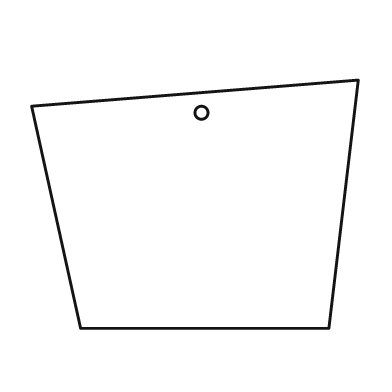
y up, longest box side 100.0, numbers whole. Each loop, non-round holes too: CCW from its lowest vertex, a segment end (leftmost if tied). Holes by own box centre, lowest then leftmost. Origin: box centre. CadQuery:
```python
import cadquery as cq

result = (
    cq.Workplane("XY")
    .moveTo(-35.0, -38.0)
    .lineTo(41.0, -38.0)
    .lineTo(50.0, 38.0)
    .lineTo(-50.0, 30.0)
    .close()
    .moveTo(2.0, 28.0)
    .circle(2.0)
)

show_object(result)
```